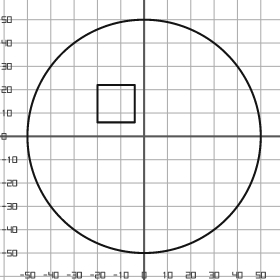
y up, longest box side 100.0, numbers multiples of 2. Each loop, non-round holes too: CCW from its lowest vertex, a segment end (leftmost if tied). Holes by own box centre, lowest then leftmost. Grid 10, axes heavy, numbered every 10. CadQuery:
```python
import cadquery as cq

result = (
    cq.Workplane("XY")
    .moveTo(0.0, 0.0)
    .circle(50.0)
    .moveTo(-20.0, 6.0)
    .lineTo(-4.0, 6.0)
    .lineTo(-4.0, 22.0)
    .lineTo(-20.0, 22.0)
    .close()
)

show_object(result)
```